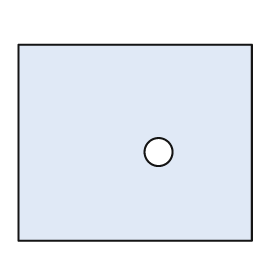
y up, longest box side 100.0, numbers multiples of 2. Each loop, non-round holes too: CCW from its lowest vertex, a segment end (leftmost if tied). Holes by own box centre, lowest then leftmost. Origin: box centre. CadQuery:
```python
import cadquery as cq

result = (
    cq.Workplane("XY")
    .moveTo(-50.0, -42.0)
    .lineTo(50.0, -42.0)
    .lineTo(50.0, 42.0)
    .lineTo(-50.0, 42.0)
    .close()
    .moveTo(10.0, -4.0)
    .circle(6.0)
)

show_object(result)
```